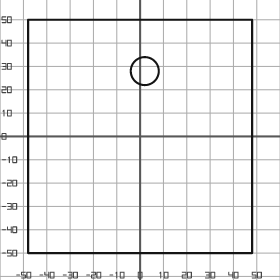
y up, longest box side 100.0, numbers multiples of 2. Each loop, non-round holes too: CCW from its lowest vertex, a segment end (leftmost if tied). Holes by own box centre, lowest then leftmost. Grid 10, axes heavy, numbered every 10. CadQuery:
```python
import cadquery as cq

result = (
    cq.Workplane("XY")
    .moveTo(-48.0, -50.0)
    .lineTo(48.0, -50.0)
    .lineTo(48.0, 50.0)
    .lineTo(-48.0, 50.0)
    .close()
    .moveTo(2.0, 28.0)
    .circle(6.0)
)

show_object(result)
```